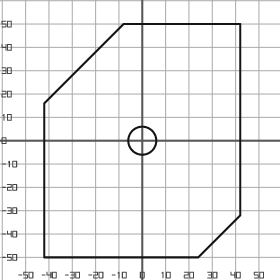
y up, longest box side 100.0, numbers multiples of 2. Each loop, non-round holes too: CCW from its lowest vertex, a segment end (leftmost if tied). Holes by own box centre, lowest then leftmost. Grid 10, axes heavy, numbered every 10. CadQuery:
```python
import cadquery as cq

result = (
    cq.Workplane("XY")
    .moveTo(-42.0, -50.0)
    .lineTo(24.0, -50.0)
    .lineTo(42.0, -32.0)
    .lineTo(42.0, 50.0)
    .lineTo(-8.0, 50.0)
    .lineTo(-42.0, 16.0)
    .close()
    .moveTo(0.0, 0.0)
    .circle(6.0)
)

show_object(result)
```